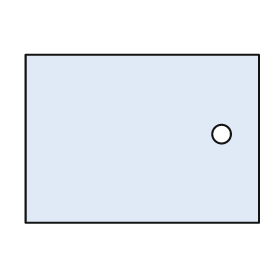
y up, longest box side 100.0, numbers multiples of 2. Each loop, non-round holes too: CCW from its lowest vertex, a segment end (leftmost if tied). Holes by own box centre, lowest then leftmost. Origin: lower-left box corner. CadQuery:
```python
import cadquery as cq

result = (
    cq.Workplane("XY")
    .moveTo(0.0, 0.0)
    .lineTo(100.0, 0.0)
    .lineTo(100.0, 72.0)
    .lineTo(0.0, 72.0)
    .close()
    .moveTo(84.0, 38.0)
    .circle(4.0)
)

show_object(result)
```